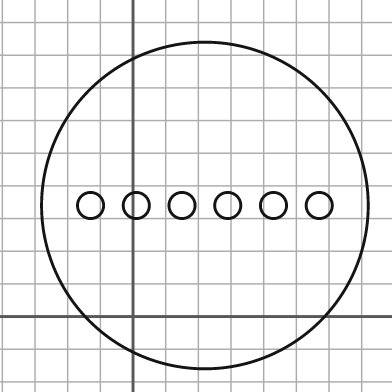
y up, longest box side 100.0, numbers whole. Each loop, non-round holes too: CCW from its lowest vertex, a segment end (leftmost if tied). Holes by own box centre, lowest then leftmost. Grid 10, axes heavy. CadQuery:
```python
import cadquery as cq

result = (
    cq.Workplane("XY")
    .moveTo(22.0, 34.0)
    .circle(50.0)
    .moveTo(-13.0, 34.0)
    .circle(4.0)
    .moveTo(1.0, 34.0)
    .circle(4.0)
    .moveTo(15.0, 34.0)
    .circle(4.0)
    .moveTo(29.0, 34.0)
    .circle(4.0)
    .moveTo(43.0, 34.0)
    .circle(4.0)
    .moveTo(57.0, 34.0)
    .circle(4.0)
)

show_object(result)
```